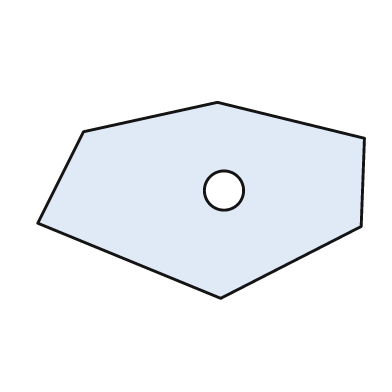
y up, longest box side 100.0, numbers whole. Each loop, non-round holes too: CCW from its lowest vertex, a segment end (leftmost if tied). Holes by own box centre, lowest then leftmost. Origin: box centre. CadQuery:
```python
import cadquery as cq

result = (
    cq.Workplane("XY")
    .moveTo(6.0, -30.0)
    .lineTo(49.0, -8.0)
    .lineTo(50.0, 19.0)
    .lineTo(5.0, 30.0)
    .lineTo(-36.0, 21.0)
    .lineTo(-50.0, -7.0)
    .close()
    .moveTo(7.0, 3.0)
    .circle(6.0)
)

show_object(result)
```